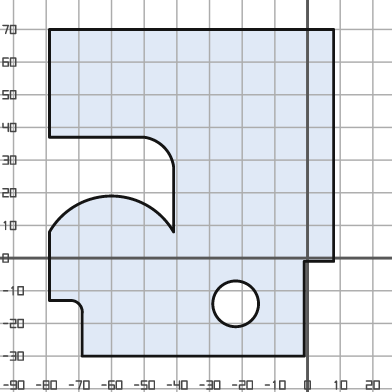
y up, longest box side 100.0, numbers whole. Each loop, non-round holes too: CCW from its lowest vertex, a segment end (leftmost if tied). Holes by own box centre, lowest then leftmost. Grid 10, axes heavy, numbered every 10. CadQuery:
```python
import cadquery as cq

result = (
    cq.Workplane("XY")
    .moveTo(-69.0, -30.0)
    .lineTo(-1.0, -30.0)
    .lineTo(-1.0, -1.0)
    .lineTo(8.0, -1.0)
    .lineTo(8.0, 70.0)
    .lineTo(-79.0, 70.0)
    .lineTo(-79.0, 37.0)
    .lineTo(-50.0, 37.0)
    .threePointArc((-44.0, 34.0), (-41.0, 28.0))
    .lineTo(-41.0, 8.0)
    .threePointArc((-60.0, 19.0), (-79.0, 8.0))
    .lineTo(-79.0, -13.0)
    .lineTo(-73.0, -13.0)
    .threePointArc((-70.0, -14.0), (-69.0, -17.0))
    .close()
    .moveTo(-22.0, -14.0)
    .circle(7.0)
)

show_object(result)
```